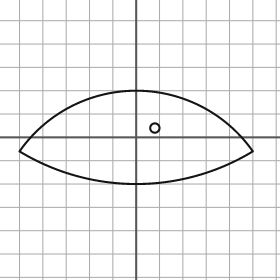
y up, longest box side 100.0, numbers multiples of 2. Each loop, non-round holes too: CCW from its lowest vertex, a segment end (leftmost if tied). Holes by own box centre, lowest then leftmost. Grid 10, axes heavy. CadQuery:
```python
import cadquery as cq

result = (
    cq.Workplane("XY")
    .moveTo(-50.0, -6.0)
    .threePointArc((0.0, -20.0), (50.0, -6.0))
    .threePointArc((0.0, 20.0), (-50.0, -6.0))
    .close()
    .moveTo(8.0, 4.0)
    .circle(2.0)
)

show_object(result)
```